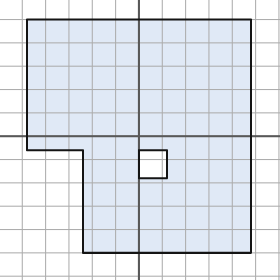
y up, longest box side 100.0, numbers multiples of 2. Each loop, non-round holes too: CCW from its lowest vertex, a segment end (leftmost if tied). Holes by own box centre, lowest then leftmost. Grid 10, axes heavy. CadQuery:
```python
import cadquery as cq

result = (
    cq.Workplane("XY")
    .moveTo(-24.0, -50.0)
    .lineTo(48.0, -50.0)
    .lineTo(48.0, 50.0)
    .lineTo(-48.0, 50.0)
    .lineTo(-48.0, -6.0)
    .lineTo(-24.0, -6.0)
    .close()
    .moveTo(0.0, -18.0)
    .lineTo(12.0, -18.0)
    .lineTo(12.0, -6.0)
    .lineTo(0.0, -6.0)
    .close()
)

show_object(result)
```